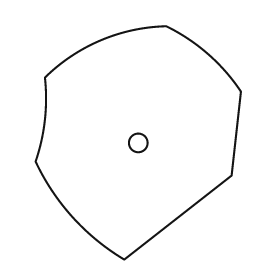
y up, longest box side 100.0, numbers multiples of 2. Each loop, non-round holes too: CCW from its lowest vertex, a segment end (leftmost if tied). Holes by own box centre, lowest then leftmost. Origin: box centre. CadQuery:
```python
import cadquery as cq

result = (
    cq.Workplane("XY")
    .moveTo(-6.0, -50.0)
    .lineTo(40.0, -14.0)
    .lineTo(44.0, 22.0)
    .threePointArc((30.0, 38.0), (12.0, 50.0))
    .threePointArc((-16.0, 44.0), (-40.0, 28.0))
    .threePointArc((-40.0, 10.0), (-44.0, -8.0))
    .threePointArc((-28.0, -32.0), (-6.0, -50.0))
    .close()
    .moveTo(0.0, 0.0)
    .circle(4.0)
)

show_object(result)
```